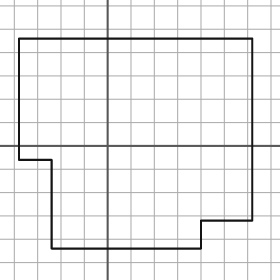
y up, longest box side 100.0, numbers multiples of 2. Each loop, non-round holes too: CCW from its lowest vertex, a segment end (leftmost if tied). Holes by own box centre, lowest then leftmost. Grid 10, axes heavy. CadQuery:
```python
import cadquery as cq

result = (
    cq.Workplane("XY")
    .moveTo(-24.0, -44.0)
    .lineTo(40.0, -44.0)
    .lineTo(40.0, -32.0)
    .lineTo(62.0, -32.0)
    .lineTo(62.0, 46.0)
    .lineTo(-38.0, 46.0)
    .lineTo(-38.0, -6.0)
    .lineTo(-24.0, -6.0)
    .close()
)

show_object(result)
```